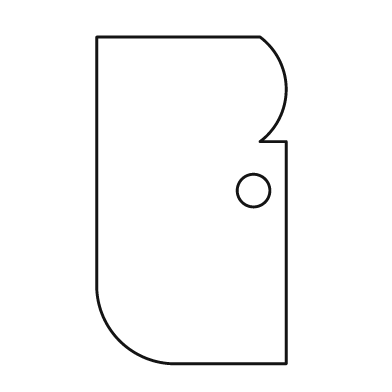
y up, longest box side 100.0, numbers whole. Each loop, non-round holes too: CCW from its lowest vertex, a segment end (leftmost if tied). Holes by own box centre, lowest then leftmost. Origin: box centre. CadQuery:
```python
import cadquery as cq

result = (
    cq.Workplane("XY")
    .moveTo(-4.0, -50.0)
    .lineTo(29.0, -50.0)
    .lineTo(29.0, 18.0)
    .lineTo(21.0, 18.0)
    .threePointArc((29.0, 34.0), (21.0, 50.0))
    .lineTo(-29.0, 50.0)
    .lineTo(-29.0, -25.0)
    .threePointArc((-22.0, -43.0), (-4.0, -50.0))
    .close()
    .moveTo(19.0, 3.0)
    .circle(5.0)
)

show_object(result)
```